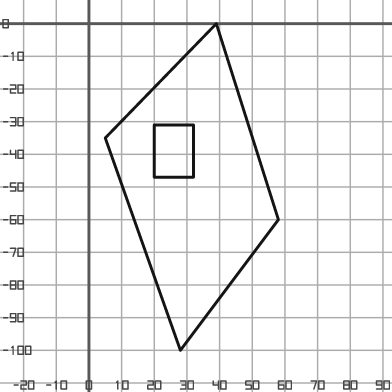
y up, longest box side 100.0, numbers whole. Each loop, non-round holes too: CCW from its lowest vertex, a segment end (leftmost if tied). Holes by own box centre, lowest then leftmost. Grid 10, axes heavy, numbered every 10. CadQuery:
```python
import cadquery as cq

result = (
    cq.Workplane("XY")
    .moveTo(28.0, -100.0)
    .lineTo(58.0, -60.0)
    .lineTo(39.0, 0.0)
    .lineTo(5.0, -35.0)
    .close()
    .moveTo(20.0, -47.0)
    .lineTo(32.0, -47.0)
    .lineTo(32.0, -31.0)
    .lineTo(20.0, -31.0)
    .close()
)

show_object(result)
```